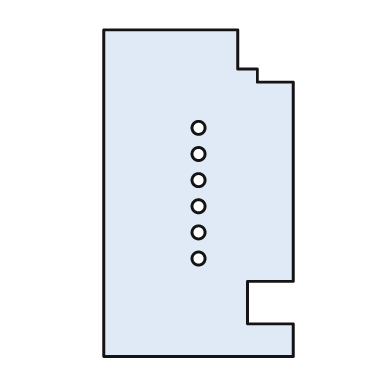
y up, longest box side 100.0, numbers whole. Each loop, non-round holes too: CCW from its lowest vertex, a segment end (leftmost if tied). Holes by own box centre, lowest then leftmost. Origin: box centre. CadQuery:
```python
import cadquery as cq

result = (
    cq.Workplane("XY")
    .moveTo(-29.0, -50.0)
    .lineTo(29.0, -50.0)
    .lineTo(29.0, -40.0)
    .lineTo(15.0, -40.0)
    .lineTo(15.0, -27.0)
    .lineTo(29.0, -27.0)
    .lineTo(29.0, 34.0)
    .lineTo(18.0, 34.0)
    .lineTo(18.0, 38.0)
    .lineTo(12.0, 38.0)
    .lineTo(12.0, 50.0)
    .lineTo(-29.0, 50.0)
    .close()
    .moveTo(0.0, -20.0)
    .circle(2.0)
    .moveTo(0.0, -12.0)
    .circle(2.0)
    .moveTo(0.0, -4.0)
    .circle(2.0)
    .moveTo(0.0, 4.0)
    .circle(2.0)
    .moveTo(0.0, 12.0)
    .circle(2.0)
    .moveTo(0.0, 20.0)
    .circle(2.0)
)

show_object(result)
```